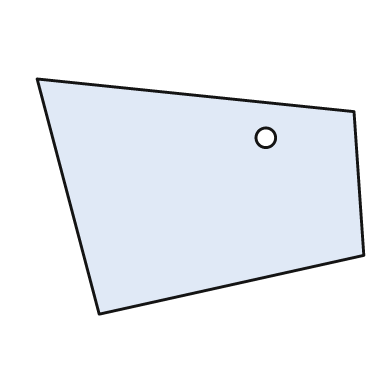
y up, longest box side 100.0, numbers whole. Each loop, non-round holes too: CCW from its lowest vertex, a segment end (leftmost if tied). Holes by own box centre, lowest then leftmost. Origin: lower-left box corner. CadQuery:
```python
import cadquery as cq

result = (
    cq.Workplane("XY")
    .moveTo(19.0, 0.0)
    .lineTo(100.0, 18.0)
    .lineTo(97.0, 62.0)
    .lineTo(0.0, 72.0)
    .close()
    .moveTo(70.0, 54.0)
    .circle(3.0)
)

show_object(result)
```